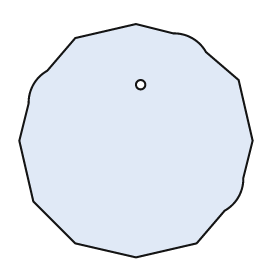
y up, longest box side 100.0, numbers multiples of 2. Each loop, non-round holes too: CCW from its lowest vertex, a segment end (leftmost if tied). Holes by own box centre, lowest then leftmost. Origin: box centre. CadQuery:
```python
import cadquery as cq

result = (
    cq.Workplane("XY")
    .moveTo(0.0, -50.0)
    .lineTo(26.0, -44.0)
    .lineTo(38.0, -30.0)
    .threePointArc((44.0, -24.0), (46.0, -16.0))
    .lineTo(50.0, 0.0)
    .lineTo(44.0, 26.0)
    .lineTo(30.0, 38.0)
    .threePointArc((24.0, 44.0), (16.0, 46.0))
    .lineTo(0.0, 50.0)
    .lineTo(-26.0, 44.0)
    .lineTo(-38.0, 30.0)
    .threePointArc((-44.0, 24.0), (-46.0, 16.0))
    .lineTo(-50.0, 0.0)
    .lineTo(-44.0, -26.0)
    .lineTo(-26.0, -44.0)
    .close()
    .moveTo(2.0, 24.0)
    .circle(2.0)
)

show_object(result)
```